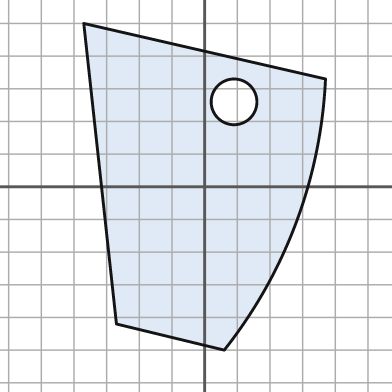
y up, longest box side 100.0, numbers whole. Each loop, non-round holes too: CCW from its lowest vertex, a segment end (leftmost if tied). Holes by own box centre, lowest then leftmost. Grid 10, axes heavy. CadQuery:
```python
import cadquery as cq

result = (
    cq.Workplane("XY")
    .moveTo(6.0, -50.0)
    .threePointArc((28.0, -11.0), (37.0, 33.0))
    .lineTo(-37.0, 50.0)
    .lineTo(-27.0, -42.0)
    .close()
    .moveTo(9.0, 26.0)
    .circle(7.0)
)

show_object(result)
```